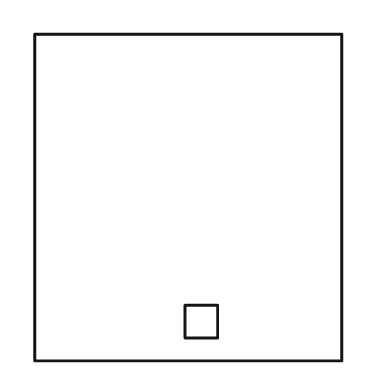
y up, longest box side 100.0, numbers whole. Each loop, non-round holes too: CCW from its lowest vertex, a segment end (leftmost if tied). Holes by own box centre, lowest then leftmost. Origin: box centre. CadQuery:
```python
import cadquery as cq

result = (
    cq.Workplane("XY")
    .moveTo(-47.0, -50.0)
    .lineTo(47.0, -50.0)
    .lineTo(47.0, 50.0)
    .lineTo(-47.0, 50.0)
    .close()
    .moveTo(-1.0, -43.0)
    .lineTo(9.0, -43.0)
    .lineTo(9.0, -33.0)
    .lineTo(-1.0, -33.0)
    .close()
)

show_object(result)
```